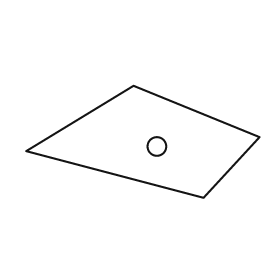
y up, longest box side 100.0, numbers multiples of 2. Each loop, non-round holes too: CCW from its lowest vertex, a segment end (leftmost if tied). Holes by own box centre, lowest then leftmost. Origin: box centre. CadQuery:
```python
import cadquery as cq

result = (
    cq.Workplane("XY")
    .moveTo(26.0, -24.0)
    .lineTo(50.0, 2.0)
    .lineTo(-4.0, 24.0)
    .lineTo(-50.0, -4.0)
    .close()
    .moveTo(6.0, -2.0)
    .circle(4.0)
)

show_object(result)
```